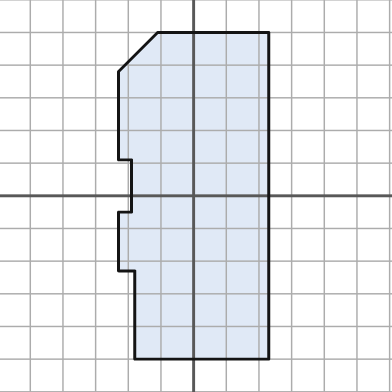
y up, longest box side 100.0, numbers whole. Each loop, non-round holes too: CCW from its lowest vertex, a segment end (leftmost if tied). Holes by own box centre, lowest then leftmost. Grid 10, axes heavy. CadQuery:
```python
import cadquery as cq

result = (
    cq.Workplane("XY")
    .moveTo(-18.0, -50.0)
    .lineTo(23.0, -50.0)
    .lineTo(23.0, 50.0)
    .lineTo(-11.0, 50.0)
    .lineTo(-23.0, 38.0)
    .lineTo(-23.0, 11.0)
    .lineTo(-19.0, 11.0)
    .lineTo(-19.0, -5.0)
    .lineTo(-23.0, -5.0)
    .lineTo(-23.0, -23.0)
    .lineTo(-18.0, -23.0)
    .close()
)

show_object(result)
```